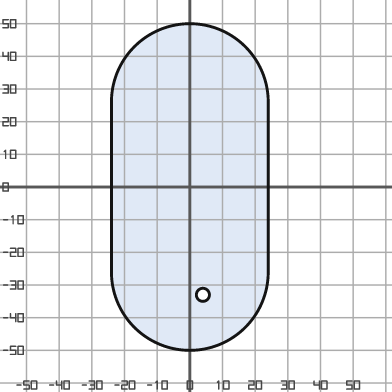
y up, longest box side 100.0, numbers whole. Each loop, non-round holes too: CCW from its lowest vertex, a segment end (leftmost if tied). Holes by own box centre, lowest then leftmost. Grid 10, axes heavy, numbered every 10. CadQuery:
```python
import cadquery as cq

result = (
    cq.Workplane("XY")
    .moveTo(-24.0, -26.0)
    .threePointArc((0.0, -50.0), (24.0, -26.0))
    .lineTo(24.0, 26.0)
    .threePointArc((0.0, 50.0), (-24.0, 26.0))
    .close()
    .moveTo(4.0, -33.0)
    .circle(2.0)
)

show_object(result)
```